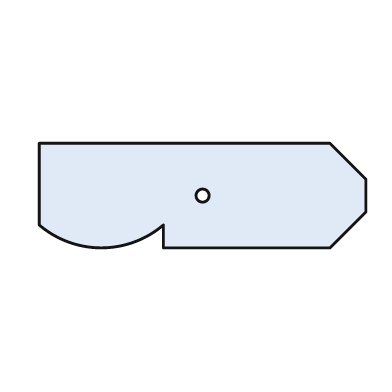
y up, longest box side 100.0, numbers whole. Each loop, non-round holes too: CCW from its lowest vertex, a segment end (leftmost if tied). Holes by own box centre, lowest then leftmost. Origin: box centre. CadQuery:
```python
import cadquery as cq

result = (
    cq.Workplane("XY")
    .moveTo(-12.0, -16.0)
    .lineTo(39.0, -16.0)
    .lineTo(50.0, -5.0)
    .lineTo(50.0, 5.0)
    .lineTo(39.0, 16.0)
    .lineTo(-50.0, 16.0)
    .lineTo(-50.0, -9.0)
    .threePointArc((-31.0, -16.0), (-12.0, -9.0))
    .close()
    .moveTo(0.0, 0.0)
    .circle(2.0)
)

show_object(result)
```